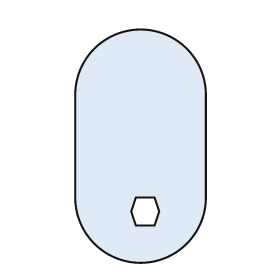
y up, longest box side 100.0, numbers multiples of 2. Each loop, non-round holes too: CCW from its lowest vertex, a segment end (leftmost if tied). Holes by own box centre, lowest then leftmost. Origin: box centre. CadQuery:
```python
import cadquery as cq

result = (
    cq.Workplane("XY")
    .moveTo(-28.0, -22.0)
    .threePointArc((0.0, -50.0), (28.0, -22.0))
    .lineTo(28.0, 22.0)
    .threePointArc((0.0, 50.0), (-28.0, 22.0))
    .close()
    .moveTo(-2.0, -34.0)
    .lineTo(6.0, -34.0)
    .lineTo(8.0, -28.0)
    .lineTo(6.0, -22.0)
    .lineTo(-2.0, -22.0)
    .lineTo(-4.0, -28.0)
    .close()
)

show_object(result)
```